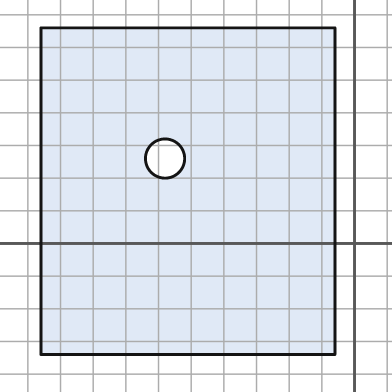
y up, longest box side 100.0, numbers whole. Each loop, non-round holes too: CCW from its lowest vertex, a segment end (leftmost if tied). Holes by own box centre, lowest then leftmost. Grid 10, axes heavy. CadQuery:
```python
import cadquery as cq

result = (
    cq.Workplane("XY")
    .moveTo(-96.0, -34.0)
    .lineTo(-6.0, -34.0)
    .lineTo(-6.0, 66.0)
    .lineTo(-96.0, 66.0)
    .close()
    .moveTo(-58.0, 26.0)
    .circle(6.0)
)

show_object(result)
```